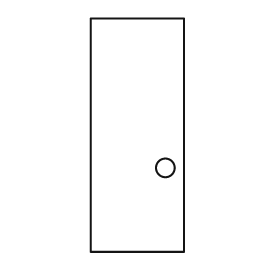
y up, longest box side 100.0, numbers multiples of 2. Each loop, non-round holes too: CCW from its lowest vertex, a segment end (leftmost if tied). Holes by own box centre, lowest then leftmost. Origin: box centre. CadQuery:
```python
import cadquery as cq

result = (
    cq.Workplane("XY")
    .moveTo(-20.0, -50.0)
    .lineTo(20.0, -50.0)
    .lineTo(20.0, 50.0)
    .lineTo(-20.0, 50.0)
    .close()
    .moveTo(12.0, -14.0)
    .circle(4.0)
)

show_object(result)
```